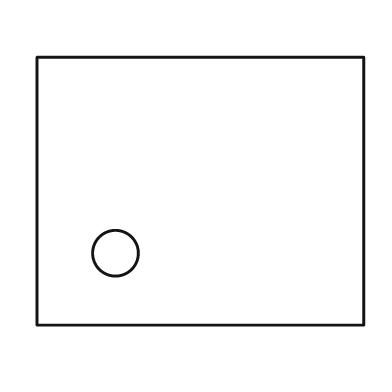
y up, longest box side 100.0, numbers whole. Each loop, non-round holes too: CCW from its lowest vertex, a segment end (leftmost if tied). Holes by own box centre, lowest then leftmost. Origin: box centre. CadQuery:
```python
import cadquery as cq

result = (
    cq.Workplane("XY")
    .moveTo(-50.0, -41.0)
    .lineTo(50.0, -41.0)
    .lineTo(50.0, 41.0)
    .lineTo(-50.0, 41.0)
    .close()
    .moveTo(-26.0, -19.0)
    .circle(7.0)
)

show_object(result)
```